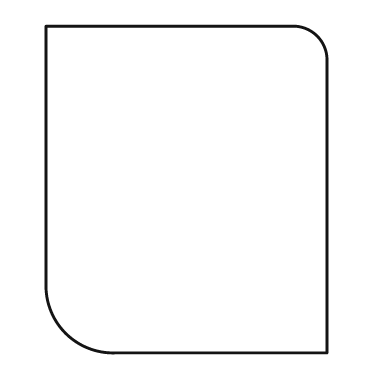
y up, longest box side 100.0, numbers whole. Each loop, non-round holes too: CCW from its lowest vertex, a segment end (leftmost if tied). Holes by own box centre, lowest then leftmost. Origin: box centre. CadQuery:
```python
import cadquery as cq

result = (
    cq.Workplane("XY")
    .moveTo(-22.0, -50.0)
    .lineTo(43.0, -50.0)
    .lineTo(43.0, 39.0)
    .threePointArc((40.0, 47.0), (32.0, 50.0))
    .lineTo(-43.0, 50.0)
    .lineTo(-43.0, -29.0)
    .threePointArc((-37.0, -44.0), (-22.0, -50.0))
    .close()
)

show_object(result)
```